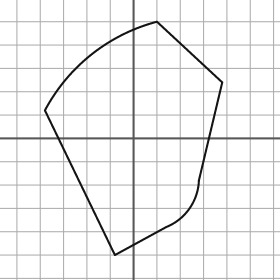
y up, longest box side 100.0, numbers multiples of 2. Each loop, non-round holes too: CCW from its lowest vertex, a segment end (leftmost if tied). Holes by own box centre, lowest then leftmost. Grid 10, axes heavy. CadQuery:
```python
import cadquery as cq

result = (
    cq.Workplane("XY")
    .moveTo(-8.0, -50.0)
    .lineTo(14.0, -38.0)
    .threePointArc((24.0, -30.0), (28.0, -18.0))
    .lineTo(38.0, 24.0)
    .lineTo(10.0, 50.0)
    .threePointArc((-18.0, 36.0), (-38.0, 12.0))
    .close()
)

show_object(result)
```